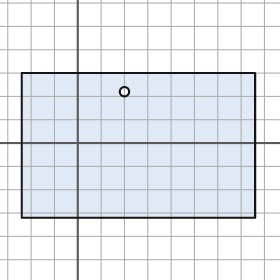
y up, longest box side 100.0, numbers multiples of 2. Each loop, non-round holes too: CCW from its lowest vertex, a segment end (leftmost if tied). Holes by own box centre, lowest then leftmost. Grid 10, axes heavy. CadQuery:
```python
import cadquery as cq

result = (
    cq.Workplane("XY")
    .moveTo(-24.0, -32.0)
    .lineTo(76.0, -32.0)
    .lineTo(76.0, 30.0)
    .lineTo(-24.0, 30.0)
    .close()
    .moveTo(20.0, 22.0)
    .circle(2.0)
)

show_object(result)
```